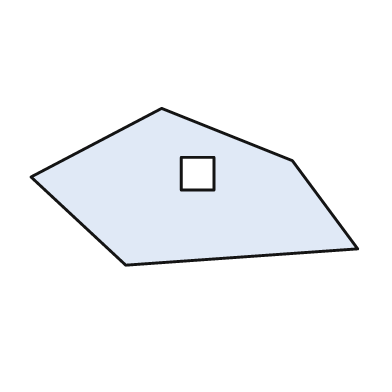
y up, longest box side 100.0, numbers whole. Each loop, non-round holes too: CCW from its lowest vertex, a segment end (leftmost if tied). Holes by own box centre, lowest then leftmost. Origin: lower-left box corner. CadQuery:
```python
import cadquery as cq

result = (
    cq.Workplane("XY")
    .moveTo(29.0, 0.0)
    .lineTo(100.0, 5.0)
    .lineTo(80.0, 32.0)
    .lineTo(40.0, 48.0)
    .lineTo(0.0, 27.0)
    .close()
    .moveTo(46.0, 23.0)
    .lineTo(56.0, 23.0)
    .lineTo(56.0, 33.0)
    .lineTo(46.0, 33.0)
    .close()
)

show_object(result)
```